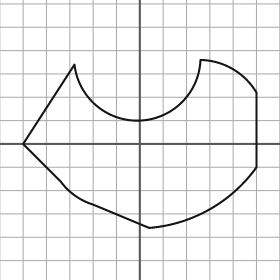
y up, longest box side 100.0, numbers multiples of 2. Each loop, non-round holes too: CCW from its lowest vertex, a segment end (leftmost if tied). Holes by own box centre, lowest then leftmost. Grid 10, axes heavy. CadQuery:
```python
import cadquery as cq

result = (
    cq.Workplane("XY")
    .moveTo(4.0, -36.0)
    .threePointArc((30.0, -28.0), (50.0, -10.0))
    .lineTo(50.0, 22.0)
    .threePointArc((40.0, 32.0), (26.0, 36.0))
    .threePointArc((0.0, 10.0), (-28.0, 34.0))
    .lineTo(-50.0, 0.0)
    .lineTo(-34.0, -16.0)
    .threePointArc((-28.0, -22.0), (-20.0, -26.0))
    .close()
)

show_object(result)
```